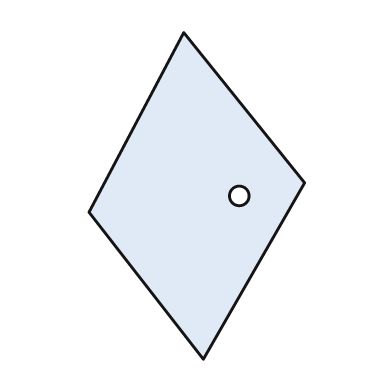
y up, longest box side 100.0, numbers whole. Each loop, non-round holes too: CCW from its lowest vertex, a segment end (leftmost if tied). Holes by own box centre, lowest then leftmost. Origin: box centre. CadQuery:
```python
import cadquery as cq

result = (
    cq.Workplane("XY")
    .moveTo(2.0, -50.0)
    .lineTo(33.0, 4.0)
    .lineTo(-4.0, 50.0)
    .lineTo(-33.0, -5.0)
    .close()
    .moveTo(13.0, 0.0)
    .circle(3.0)
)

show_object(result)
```